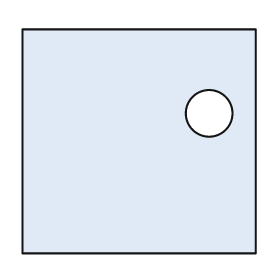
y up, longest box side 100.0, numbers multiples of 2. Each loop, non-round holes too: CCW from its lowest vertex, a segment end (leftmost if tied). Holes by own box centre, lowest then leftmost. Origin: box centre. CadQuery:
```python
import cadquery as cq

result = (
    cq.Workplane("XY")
    .moveTo(-50.0, -48.0)
    .lineTo(50.0, -48.0)
    .lineTo(50.0, 48.0)
    .lineTo(-50.0, 48.0)
    .close()
    .moveTo(30.0, 12.0)
    .circle(10.0)
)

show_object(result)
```